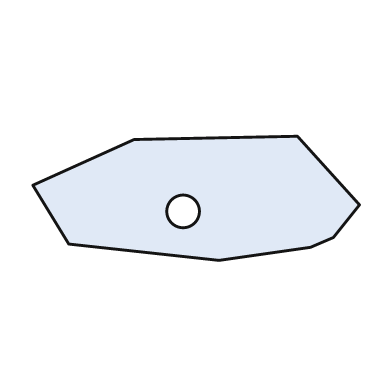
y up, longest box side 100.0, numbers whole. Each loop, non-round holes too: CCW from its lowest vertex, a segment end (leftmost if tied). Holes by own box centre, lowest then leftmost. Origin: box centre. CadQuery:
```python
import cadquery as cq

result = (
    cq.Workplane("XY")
    .moveTo(7.0, -19.0)
    .lineTo(35.0, -15.0)
    .lineTo(42.0, -12.0)
    .lineTo(50.0, -2.0)
    .lineTo(31.0, 19.0)
    .lineTo(-19.0, 18.0)
    .lineTo(-50.0, 4.0)
    .lineTo(-39.0, -14.0)
    .close()
    .moveTo(-4.0, -4.0)
    .circle(5.0)
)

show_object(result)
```